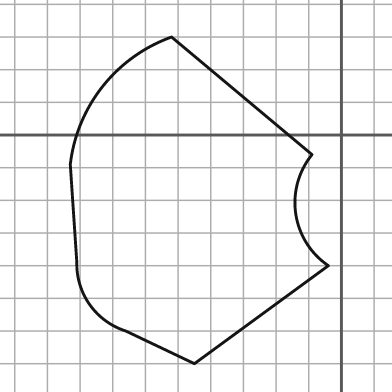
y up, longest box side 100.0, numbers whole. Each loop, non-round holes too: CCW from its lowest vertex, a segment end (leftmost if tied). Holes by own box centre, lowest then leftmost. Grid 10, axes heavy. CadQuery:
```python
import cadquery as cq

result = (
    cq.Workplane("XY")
    .moveTo(-45.0, -70.0)
    .lineTo(-4.0, -40.0)
    .threePointArc((-14.0, -24.0), (-9.0, -6.0))
    .lineTo(-52.0, 30.0)
    .threePointArc((-73.0, 15.0), (-83.0, -9.0))
    .lineTo(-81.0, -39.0)
    .threePointArc((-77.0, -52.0), (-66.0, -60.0))
    .close()
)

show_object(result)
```